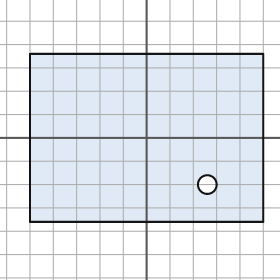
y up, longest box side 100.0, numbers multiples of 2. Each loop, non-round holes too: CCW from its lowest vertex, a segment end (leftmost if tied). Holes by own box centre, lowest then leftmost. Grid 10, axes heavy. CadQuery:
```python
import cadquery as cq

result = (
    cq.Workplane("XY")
    .moveTo(-50.0, -36.0)
    .lineTo(50.0, -36.0)
    .lineTo(50.0, 36.0)
    .lineTo(-50.0, 36.0)
    .close()
    .moveTo(26.0, -20.0)
    .circle(4.0)
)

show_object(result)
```